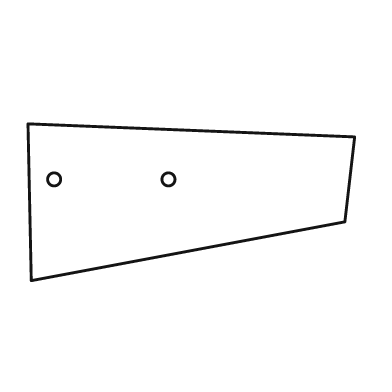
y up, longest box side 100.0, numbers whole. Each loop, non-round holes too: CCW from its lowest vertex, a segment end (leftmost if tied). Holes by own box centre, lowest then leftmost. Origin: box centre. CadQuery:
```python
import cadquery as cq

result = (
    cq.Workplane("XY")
    .moveTo(-49.0, -24.0)
    .lineTo(47.0, -6.0)
    .lineTo(50.0, 20.0)
    .lineTo(-50.0, 24.0)
    .close()
    .moveTo(-42.0, 7.0)
    .circle(2.0)
    .moveTo(-7.0, 7.0)
    .circle(2.0)
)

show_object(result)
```